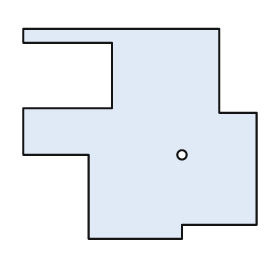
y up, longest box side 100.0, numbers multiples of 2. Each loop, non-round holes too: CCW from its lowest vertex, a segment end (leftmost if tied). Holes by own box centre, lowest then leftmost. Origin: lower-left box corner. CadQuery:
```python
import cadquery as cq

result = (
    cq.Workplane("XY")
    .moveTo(28.0, 0.0)
    .lineTo(68.0, 0.0)
    .lineTo(68.0, 6.0)
    .lineTo(100.0, 6.0)
    .lineTo(100.0, 54.0)
    .lineTo(84.0, 54.0)
    .lineTo(84.0, 90.0)
    .lineTo(0.0, 90.0)
    .lineTo(0.0, 84.0)
    .lineTo(38.0, 84.0)
    .lineTo(38.0, 56.0)
    .lineTo(0.0, 56.0)
    .lineTo(0.0, 36.0)
    .lineTo(28.0, 36.0)
    .close()
    .moveTo(68.0, 36.0)
    .circle(2.0)
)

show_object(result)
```